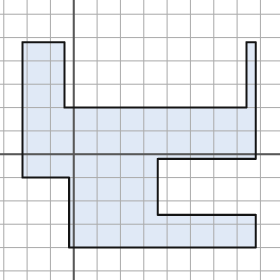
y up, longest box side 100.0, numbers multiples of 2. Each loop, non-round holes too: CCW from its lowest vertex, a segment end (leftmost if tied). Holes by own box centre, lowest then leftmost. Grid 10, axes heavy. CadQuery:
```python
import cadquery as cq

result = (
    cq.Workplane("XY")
    .moveTo(-2.0, -40.0)
    .lineTo(78.0, -40.0)
    .lineTo(78.0, -26.0)
    .lineTo(36.0, -26.0)
    .lineTo(36.0, -2.0)
    .lineTo(78.0, -2.0)
    .lineTo(78.0, 48.0)
    .lineTo(74.0, 48.0)
    .lineTo(74.0, 20.0)
    .lineTo(-4.0, 20.0)
    .lineTo(-4.0, 48.0)
    .lineTo(-22.0, 48.0)
    .lineTo(-22.0, -10.0)
    .lineTo(-2.0, -10.0)
    .close()
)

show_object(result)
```